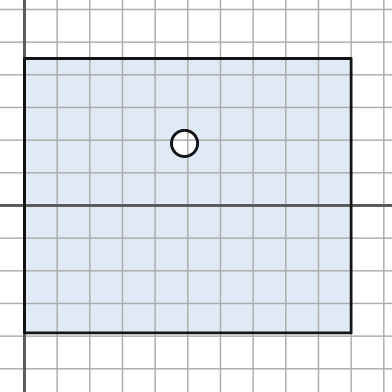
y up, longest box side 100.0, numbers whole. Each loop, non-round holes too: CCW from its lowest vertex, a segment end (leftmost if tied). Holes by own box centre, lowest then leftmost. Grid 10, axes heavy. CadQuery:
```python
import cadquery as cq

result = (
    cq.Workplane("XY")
    .moveTo(0.0, -39.0)
    .lineTo(100.0, -39.0)
    .lineTo(100.0, 45.0)
    .lineTo(0.0, 45.0)
    .close()
    .moveTo(49.0, 19.0)
    .circle(4.0)
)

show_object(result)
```